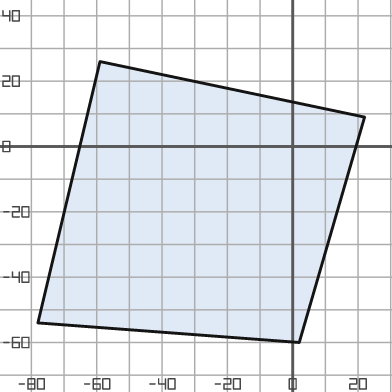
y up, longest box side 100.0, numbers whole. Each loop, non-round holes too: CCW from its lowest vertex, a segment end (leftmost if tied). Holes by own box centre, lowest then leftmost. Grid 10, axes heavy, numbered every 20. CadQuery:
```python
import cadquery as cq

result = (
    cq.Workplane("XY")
    .moveTo(2.0, -60.0)
    .lineTo(22.0, 9.0)
    .lineTo(-59.0, 26.0)
    .lineTo(-78.0, -54.0)
    .close()
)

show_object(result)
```